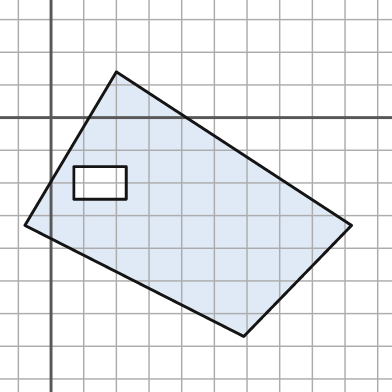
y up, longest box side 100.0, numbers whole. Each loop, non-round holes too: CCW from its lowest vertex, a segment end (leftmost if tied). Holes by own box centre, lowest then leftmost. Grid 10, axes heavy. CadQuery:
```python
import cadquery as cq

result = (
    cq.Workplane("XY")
    .moveTo(59.0, -67.0)
    .lineTo(92.0, -33.0)
    .lineTo(20.0, 14.0)
    .lineTo(-8.0, -33.0)
    .close()
    .moveTo(7.0, -25.0)
    .lineTo(23.0, -25.0)
    .lineTo(23.0, -15.0)
    .lineTo(7.0, -15.0)
    .close()
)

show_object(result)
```